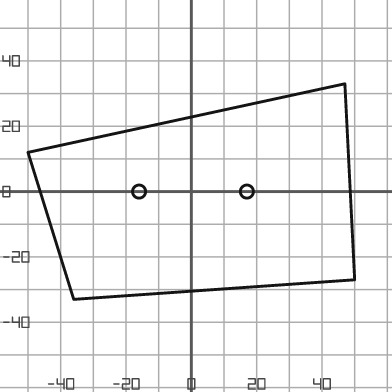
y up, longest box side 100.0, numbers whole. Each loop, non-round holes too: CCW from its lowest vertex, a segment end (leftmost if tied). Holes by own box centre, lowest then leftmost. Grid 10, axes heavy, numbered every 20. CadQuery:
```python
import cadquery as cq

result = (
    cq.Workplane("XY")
    .moveTo(-36.0, -33.0)
    .lineTo(50.0, -27.0)
    .lineTo(47.0, 33.0)
    .lineTo(-50.0, 12.0)
    .close()
    .moveTo(-16.0, 0.0)
    .circle(2.0)
    .moveTo(17.0, 0.0)
    .circle(2.0)
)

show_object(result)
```